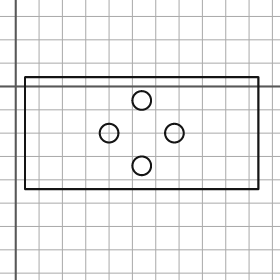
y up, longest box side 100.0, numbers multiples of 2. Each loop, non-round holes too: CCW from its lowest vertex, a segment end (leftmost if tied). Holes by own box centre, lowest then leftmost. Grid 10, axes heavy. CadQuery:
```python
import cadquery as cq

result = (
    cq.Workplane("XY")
    .moveTo(4.0, -44.0)
    .lineTo(104.0, -44.0)
    .lineTo(104.0, 4.0)
    .lineTo(4.0, 4.0)
    .close()
    .moveTo(54.0, -34.0)
    .circle(4.0)
    .moveTo(40.0, -20.0)
    .circle(4.0)
    .moveTo(68.0, -20.0)
    .circle(4.0)
    .moveTo(54.0, -6.0)
    .circle(4.0)
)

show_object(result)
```